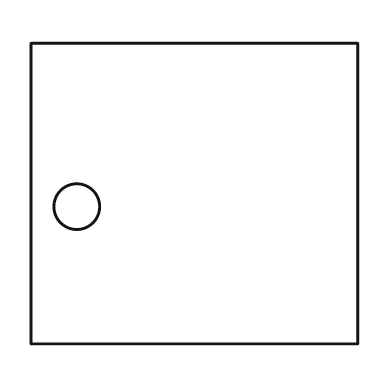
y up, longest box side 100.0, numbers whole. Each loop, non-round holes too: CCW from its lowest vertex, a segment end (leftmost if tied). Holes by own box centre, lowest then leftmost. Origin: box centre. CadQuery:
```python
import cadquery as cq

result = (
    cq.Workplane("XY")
    .moveTo(-50.0, -46.0)
    .lineTo(50.0, -46.0)
    .lineTo(50.0, 46.0)
    .lineTo(-50.0, 46.0)
    .close()
    .moveTo(-36.0, -4.0)
    .circle(7.0)
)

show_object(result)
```